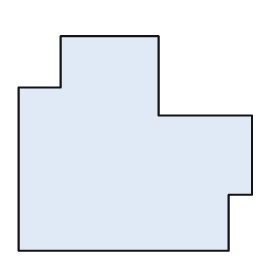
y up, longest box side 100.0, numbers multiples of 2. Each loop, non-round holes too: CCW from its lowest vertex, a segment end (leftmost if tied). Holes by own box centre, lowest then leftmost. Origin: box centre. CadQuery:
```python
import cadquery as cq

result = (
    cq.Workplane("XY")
    .moveTo(-50.0, -46.0)
    .lineTo(40.0, -46.0)
    .lineTo(40.0, -22.0)
    .lineTo(50.0, -22.0)
    .lineTo(50.0, 12.0)
    .lineTo(10.0, 12.0)
    .lineTo(10.0, 46.0)
    .lineTo(-32.0, 46.0)
    .lineTo(-32.0, 24.0)
    .lineTo(-50.0, 24.0)
    .close()
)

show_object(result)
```